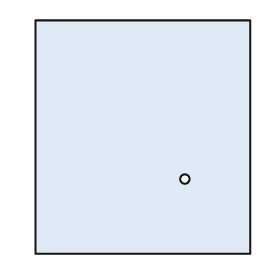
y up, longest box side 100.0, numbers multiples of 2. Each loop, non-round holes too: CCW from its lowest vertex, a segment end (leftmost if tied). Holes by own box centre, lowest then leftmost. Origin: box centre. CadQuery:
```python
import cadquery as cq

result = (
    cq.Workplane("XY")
    .moveTo(-46.0, -50.0)
    .lineTo(46.0, -50.0)
    .lineTo(46.0, 50.0)
    .lineTo(-46.0, 50.0)
    .close()
    .moveTo(18.0, -18.0)
    .circle(2.0)
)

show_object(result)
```